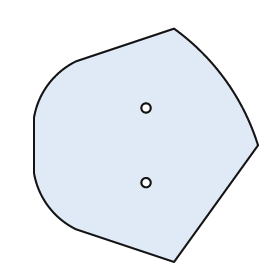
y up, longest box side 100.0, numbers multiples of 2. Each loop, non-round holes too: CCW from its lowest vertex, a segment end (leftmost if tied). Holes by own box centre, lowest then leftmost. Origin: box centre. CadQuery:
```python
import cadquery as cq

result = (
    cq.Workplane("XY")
    .moveTo(12.0, -50.0)
    .lineTo(48.0, 0.0)
    .threePointArc((34.0, 28.0), (12.0, 50.0))
    .lineTo(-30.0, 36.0)
    .threePointArc((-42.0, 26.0), (-48.0, 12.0))
    .lineTo(-48.0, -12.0)
    .threePointArc((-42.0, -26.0), (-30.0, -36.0))
    .close()
    .moveTo(0.0, -16.0)
    .circle(2.0)
    .moveTo(0.0, 16.0)
    .circle(2.0)
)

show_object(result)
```